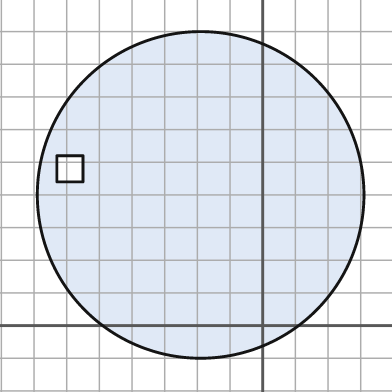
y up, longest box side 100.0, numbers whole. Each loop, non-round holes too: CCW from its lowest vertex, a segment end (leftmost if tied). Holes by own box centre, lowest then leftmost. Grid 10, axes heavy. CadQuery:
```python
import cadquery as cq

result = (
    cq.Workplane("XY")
    .moveTo(-19.0, 40.0)
    .circle(50.0)
    .moveTo(-63.0, 44.0)
    .lineTo(-55.0, 44.0)
    .lineTo(-55.0, 52.0)
    .lineTo(-63.0, 52.0)
    .close()
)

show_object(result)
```